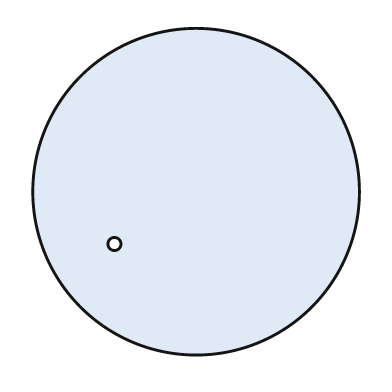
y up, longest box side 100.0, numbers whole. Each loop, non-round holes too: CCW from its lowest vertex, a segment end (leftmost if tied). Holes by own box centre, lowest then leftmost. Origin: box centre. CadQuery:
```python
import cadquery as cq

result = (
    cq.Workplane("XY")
    .moveTo(0.0, 0.0)
    .circle(50.0)
    .moveTo(-25.0, -16.0)
    .circle(2.0)
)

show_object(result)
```